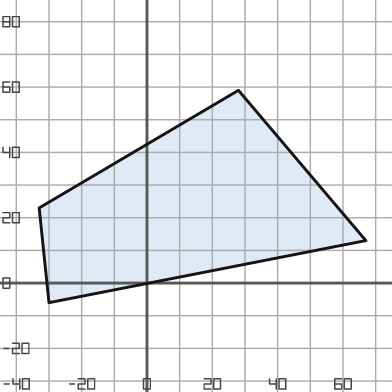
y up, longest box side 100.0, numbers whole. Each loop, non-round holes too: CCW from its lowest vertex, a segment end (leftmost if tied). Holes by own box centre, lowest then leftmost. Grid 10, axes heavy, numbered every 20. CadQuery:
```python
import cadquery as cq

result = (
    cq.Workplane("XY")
    .moveTo(-30.0, -6.0)
    .lineTo(67.0, 13.0)
    .lineTo(28.0, 59.0)
    .lineTo(-33.0, 23.0)
    .close()
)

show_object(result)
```